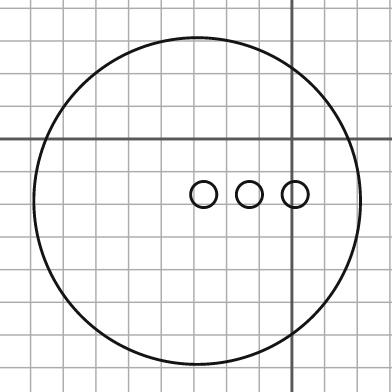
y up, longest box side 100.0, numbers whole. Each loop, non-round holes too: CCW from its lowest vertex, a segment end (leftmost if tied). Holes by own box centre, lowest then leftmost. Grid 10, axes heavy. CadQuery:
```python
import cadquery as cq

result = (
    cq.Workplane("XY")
    .moveTo(-29.0, -19.0)
    .circle(50.0)
    .moveTo(-27.0, -17.0)
    .circle(4.0)
    .moveTo(-13.0, -17.0)
    .circle(4.0)
    .moveTo(1.0, -17.0)
    .circle(4.0)
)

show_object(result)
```